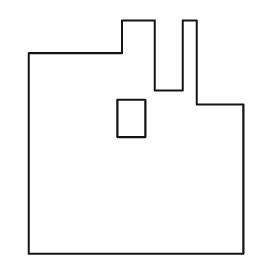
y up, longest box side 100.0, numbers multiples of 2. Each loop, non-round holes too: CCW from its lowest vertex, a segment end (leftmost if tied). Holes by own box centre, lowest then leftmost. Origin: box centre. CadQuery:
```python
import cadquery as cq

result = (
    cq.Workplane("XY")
    .moveTo(-46.0, -50.0)
    .lineTo(46.0, -50.0)
    .lineTo(46.0, 14.0)
    .lineTo(26.0, 14.0)
    .lineTo(26.0, 50.0)
    .lineTo(20.0, 50.0)
    .lineTo(20.0, 20.0)
    .lineTo(8.0, 20.0)
    .lineTo(8.0, 50.0)
    .lineTo(-6.0, 50.0)
    .lineTo(-6.0, 36.0)
    .lineTo(-46.0, 36.0)
    .close()
    .moveTo(-8.0, 0.0)
    .lineTo(4.0, 0.0)
    .lineTo(4.0, 16.0)
    .lineTo(-8.0, 16.0)
    .close()
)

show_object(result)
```